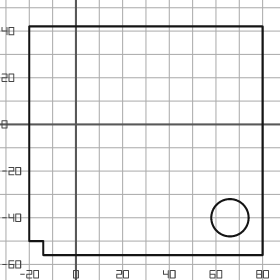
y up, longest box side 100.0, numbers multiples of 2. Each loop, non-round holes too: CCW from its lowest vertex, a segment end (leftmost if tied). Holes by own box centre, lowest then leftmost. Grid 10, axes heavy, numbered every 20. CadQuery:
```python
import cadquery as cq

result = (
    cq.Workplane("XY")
    .moveTo(-14.0, -56.0)
    .lineTo(80.0, -56.0)
    .lineTo(80.0, 42.0)
    .lineTo(-20.0, 42.0)
    .lineTo(-20.0, -50.0)
    .lineTo(-14.0, -50.0)
    .close()
    .moveTo(66.0, -40.0)
    .circle(8.0)
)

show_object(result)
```